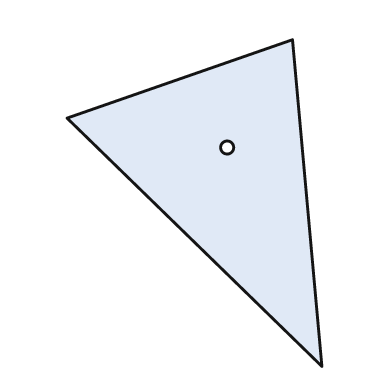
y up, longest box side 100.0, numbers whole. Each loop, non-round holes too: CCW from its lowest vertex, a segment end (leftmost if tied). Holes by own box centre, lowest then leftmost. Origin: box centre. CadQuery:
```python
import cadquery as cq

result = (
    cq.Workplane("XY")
    .moveTo(39.0, -50.0)
    .lineTo(30.0, 50.0)
    .lineTo(-39.0, 26.0)
    .close()
    .moveTo(10.0, 17.0)
    .circle(2.0)
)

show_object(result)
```